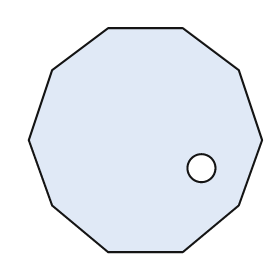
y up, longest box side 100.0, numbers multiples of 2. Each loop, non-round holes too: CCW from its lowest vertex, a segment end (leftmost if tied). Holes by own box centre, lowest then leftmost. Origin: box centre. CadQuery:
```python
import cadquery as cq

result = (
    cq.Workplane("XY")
    .moveTo(-16.0, -48.0)
    .lineTo(16.0, -48.0)
    .lineTo(40.0, -28.0)
    .lineTo(50.0, 0.0)
    .lineTo(40.0, 30.0)
    .lineTo(16.0, 48.0)
    .lineTo(-16.0, 48.0)
    .lineTo(-40.0, 30.0)
    .lineTo(-50.0, 0.0)
    .lineTo(-40.0, -28.0)
    .close()
    .moveTo(24.0, -12.0)
    .circle(6.0)
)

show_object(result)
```